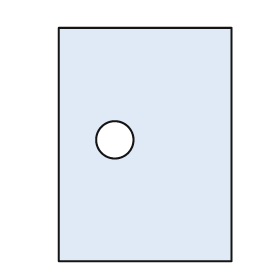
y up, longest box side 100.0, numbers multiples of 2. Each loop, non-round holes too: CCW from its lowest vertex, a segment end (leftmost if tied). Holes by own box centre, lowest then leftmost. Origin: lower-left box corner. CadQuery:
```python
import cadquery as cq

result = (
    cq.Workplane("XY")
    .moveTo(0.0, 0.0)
    .lineTo(74.0, 0.0)
    .lineTo(74.0, 100.0)
    .lineTo(0.0, 100.0)
    .close()
    .moveTo(24.0, 52.0)
    .circle(8.0)
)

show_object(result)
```